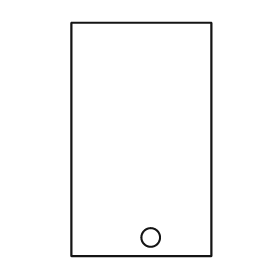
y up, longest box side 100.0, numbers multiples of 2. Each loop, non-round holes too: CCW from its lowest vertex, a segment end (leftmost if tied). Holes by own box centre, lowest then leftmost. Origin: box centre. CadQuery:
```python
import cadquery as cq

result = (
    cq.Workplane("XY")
    .moveTo(-30.0, -50.0)
    .lineTo(30.0, -50.0)
    .lineTo(30.0, 50.0)
    .lineTo(-30.0, 50.0)
    .close()
    .moveTo(4.0, -42.0)
    .circle(4.0)
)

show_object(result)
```